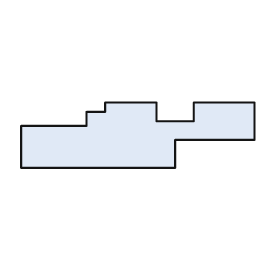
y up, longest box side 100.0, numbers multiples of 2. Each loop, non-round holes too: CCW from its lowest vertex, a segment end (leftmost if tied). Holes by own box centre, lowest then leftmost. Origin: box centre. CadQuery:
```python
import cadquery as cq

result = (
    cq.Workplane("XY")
    .moveTo(-50.0, -14.0)
    .lineTo(16.0, -14.0)
    .lineTo(16.0, -2.0)
    .lineTo(50.0, -2.0)
    .lineTo(50.0, 14.0)
    .lineTo(24.0, 14.0)
    .lineTo(24.0, 6.0)
    .lineTo(8.0, 6.0)
    .lineTo(8.0, 14.0)
    .lineTo(-14.0, 14.0)
    .lineTo(-14.0, 10.0)
    .lineTo(-22.0, 10.0)
    .lineTo(-22.0, 4.0)
    .lineTo(-50.0, 4.0)
    .close()
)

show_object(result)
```